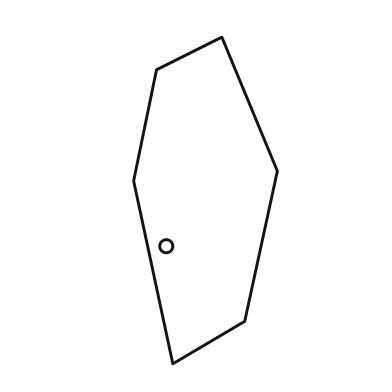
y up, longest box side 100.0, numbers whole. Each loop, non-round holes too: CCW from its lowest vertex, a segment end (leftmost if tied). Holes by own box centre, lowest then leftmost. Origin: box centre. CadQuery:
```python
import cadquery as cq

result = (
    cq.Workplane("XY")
    .moveTo(-10.0, -50.0)
    .lineTo(12.0, -37.0)
    .lineTo(22.0, 9.0)
    .lineTo(5.0, 50.0)
    .lineTo(-15.0, 40.0)
    .lineTo(-22.0, 6.0)
    .close()
    .moveTo(-12.0, -14.0)
    .circle(2.0)
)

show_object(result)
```